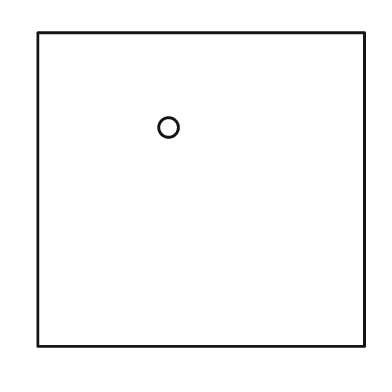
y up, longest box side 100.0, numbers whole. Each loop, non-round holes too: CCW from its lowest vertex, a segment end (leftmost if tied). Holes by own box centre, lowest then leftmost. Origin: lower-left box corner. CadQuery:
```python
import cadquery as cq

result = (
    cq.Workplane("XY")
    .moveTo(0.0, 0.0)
    .lineTo(100.0, 0.0)
    .lineTo(100.0, 96.0)
    .lineTo(0.0, 96.0)
    .close()
    .moveTo(40.0, 67.0)
    .circle(3.0)
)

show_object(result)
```